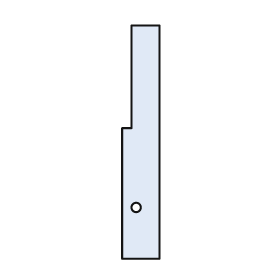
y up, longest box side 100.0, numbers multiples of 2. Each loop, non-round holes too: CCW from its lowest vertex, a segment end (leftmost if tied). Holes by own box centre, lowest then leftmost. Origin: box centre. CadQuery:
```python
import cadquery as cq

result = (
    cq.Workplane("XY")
    .moveTo(-8.0, -50.0)
    .lineTo(8.0, -50.0)
    .lineTo(8.0, 50.0)
    .lineTo(-4.0, 50.0)
    .lineTo(-4.0, 6.0)
    .lineTo(-8.0, 6.0)
    .close()
    .moveTo(-2.0, -28.0)
    .circle(2.0)
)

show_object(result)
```